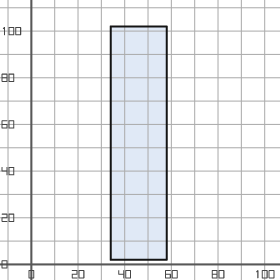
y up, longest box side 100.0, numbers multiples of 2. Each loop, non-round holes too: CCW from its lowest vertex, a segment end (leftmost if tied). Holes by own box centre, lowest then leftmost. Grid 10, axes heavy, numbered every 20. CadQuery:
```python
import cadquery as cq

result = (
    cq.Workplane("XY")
    .moveTo(34.0, 2.0)
    .lineTo(58.0, 2.0)
    .lineTo(58.0, 102.0)
    .lineTo(34.0, 102.0)
    .close()
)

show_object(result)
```